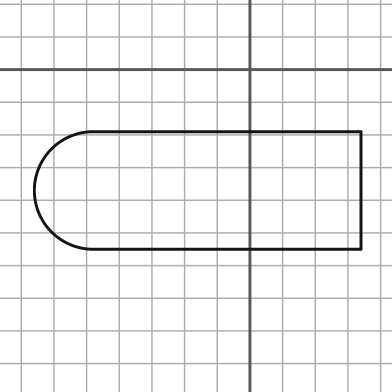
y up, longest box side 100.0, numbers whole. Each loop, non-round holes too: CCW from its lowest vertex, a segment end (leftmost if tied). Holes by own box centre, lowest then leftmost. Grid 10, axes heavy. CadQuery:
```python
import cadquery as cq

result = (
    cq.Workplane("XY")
    .moveTo(-48.0, -55.0)
    .lineTo(34.0, -55.0)
    .lineTo(34.0, -19.0)
    .lineTo(-48.0, -19.0)
    .threePointArc((-66.0, -37.0), (-48.0, -55.0))
    .close()
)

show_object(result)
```